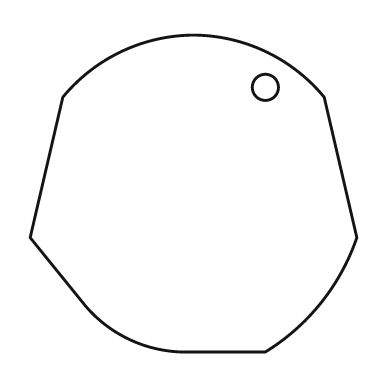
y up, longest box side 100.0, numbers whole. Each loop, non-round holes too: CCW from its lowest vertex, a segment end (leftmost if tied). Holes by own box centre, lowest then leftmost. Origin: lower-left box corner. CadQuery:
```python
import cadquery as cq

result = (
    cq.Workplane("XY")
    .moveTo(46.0, 0.0)
    .lineTo(72.0, 0.0)
    .threePointArc((89.0, 15.0), (100.0, 35.0))
    .lineTo(90.0, 78.0)
    .threePointArc((72.0, 92.0), (50.0, 97.0))
    .threePointArc((28.0, 92.0), (10.0, 78.0))
    .lineTo(0.0, 35.0)
    .lineTo(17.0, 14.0)
    .threePointArc((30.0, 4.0), (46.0, 0.0))
    .close()
    .moveTo(72.0, 81.0)
    .circle(4.0)
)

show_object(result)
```